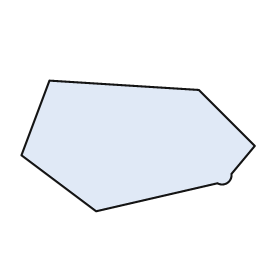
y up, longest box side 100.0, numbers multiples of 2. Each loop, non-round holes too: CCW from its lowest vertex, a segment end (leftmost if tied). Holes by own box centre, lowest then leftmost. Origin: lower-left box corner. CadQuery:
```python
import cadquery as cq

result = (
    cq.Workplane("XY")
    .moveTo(32.0, 0.0)
    .lineTo(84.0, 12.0)
    .threePointArc((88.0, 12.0), (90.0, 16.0))
    .lineTo(100.0, 28.0)
    .lineTo(76.0, 52.0)
    .lineTo(12.0, 56.0)
    .lineTo(0.0, 24.0)
    .close()
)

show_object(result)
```